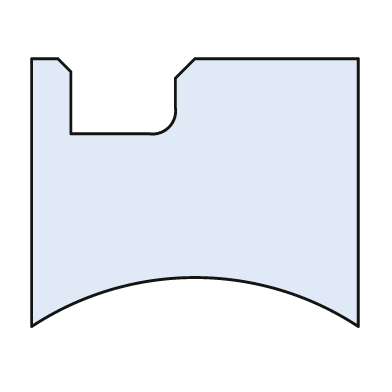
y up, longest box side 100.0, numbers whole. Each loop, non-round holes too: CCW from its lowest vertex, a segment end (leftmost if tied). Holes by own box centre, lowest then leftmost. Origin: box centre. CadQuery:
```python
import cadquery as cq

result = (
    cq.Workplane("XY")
    .moveTo(-50.0, -41.0)
    .threePointArc((0.0, -26.0), (50.0, -41.0))
    .lineTo(50.0, 41.0)
    .lineTo(0.0, 41.0)
    .lineTo(-6.0, 35.0)
    .lineTo(-6.0, 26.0)
    .threePointArc((-8.0, 20.0), (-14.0, 18.0))
    .lineTo(-38.0, 18.0)
    .lineTo(-38.0, 37.0)
    .lineTo(-42.0, 41.0)
    .lineTo(-50.0, 41.0)
    .close()
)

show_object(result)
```